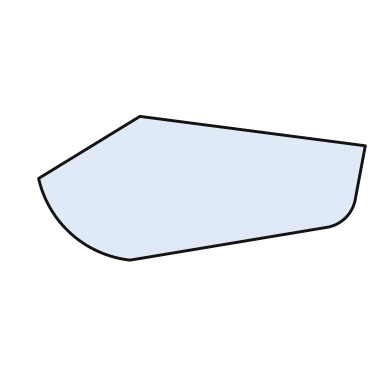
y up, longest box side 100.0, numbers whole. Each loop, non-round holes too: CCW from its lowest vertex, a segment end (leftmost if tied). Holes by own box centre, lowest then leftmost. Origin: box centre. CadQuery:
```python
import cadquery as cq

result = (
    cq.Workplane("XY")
    .moveTo(-22.0, -22.0)
    .lineTo(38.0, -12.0)
    .threePointArc((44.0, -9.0), (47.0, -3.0))
    .lineTo(50.0, 13.0)
    .lineTo(-19.0, 22.0)
    .lineTo(-50.0, 3.0)
    .threePointArc((-40.0, -14.0), (-22.0, -22.0))
    .close()
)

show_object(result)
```